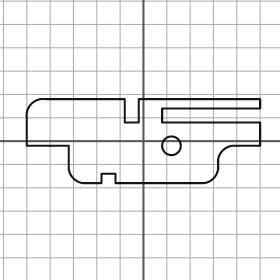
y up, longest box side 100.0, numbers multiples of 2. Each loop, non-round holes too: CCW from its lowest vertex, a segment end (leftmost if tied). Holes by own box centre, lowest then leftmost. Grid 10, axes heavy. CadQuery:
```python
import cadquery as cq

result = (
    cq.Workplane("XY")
    .moveTo(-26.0, -18.0)
    .lineTo(-18.0, -18.0)
    .lineTo(-18.0, -14.0)
    .lineTo(-12.0, -14.0)
    .lineTo(-12.0, -18.0)
    .lineTo(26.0, -18.0)
    .threePointArc((30.0, -16.0), (32.0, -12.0))
    .lineTo(32.0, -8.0)
    .threePointArc((34.0, -4.0), (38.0, -2.0))
    .lineTo(50.0, -2.0)
    .lineTo(50.0, 8.0)
    .lineTo(8.0, 8.0)
    .lineTo(8.0, 14.0)
    .lineTo(50.0, 14.0)
    .lineTo(50.0, 18.0)
    .lineTo(-2.0, 18.0)
    .lineTo(-2.0, 8.0)
    .lineTo(-8.0, 8.0)
    .lineTo(-8.0, 18.0)
    .lineTo(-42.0, 18.0)
    .threePointArc((-48.0, 16.0), (-50.0, 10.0))
    .lineTo(-50.0, -2.0)
    .lineTo(-32.0, -2.0)
    .lineTo(-32.0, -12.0)
    .threePointArc((-30.0, -16.0), (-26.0, -18.0))
    .close()
    .moveTo(12.0, -2.0)
    .circle(4.0)
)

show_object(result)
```